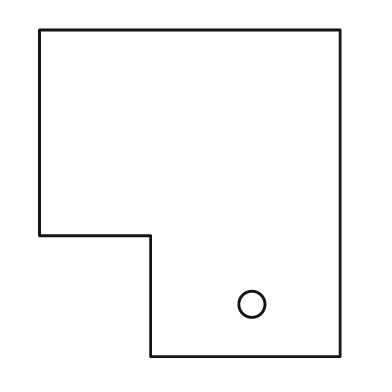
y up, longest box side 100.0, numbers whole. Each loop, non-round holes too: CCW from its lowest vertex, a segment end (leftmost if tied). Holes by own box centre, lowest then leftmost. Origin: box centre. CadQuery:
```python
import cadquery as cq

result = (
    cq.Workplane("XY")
    .moveTo(-12.0, -50.0)
    .lineTo(46.0, -50.0)
    .lineTo(46.0, 50.0)
    .lineTo(-46.0, 50.0)
    .lineTo(-46.0, -13.0)
    .lineTo(-12.0, -13.0)
    .close()
    .moveTo(19.0, -34.0)
    .circle(4.0)
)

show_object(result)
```